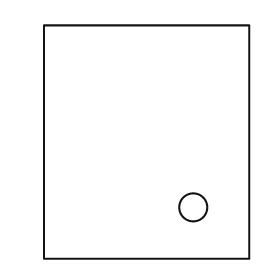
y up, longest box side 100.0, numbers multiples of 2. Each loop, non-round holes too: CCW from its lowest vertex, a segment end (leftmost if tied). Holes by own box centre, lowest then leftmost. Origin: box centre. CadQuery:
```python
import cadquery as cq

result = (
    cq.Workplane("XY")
    .moveTo(-44.0, -50.0)
    .lineTo(44.0, -50.0)
    .lineTo(44.0, 50.0)
    .lineTo(-44.0, 50.0)
    .close()
    .moveTo(20.0, -28.0)
    .circle(6.0)
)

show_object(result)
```